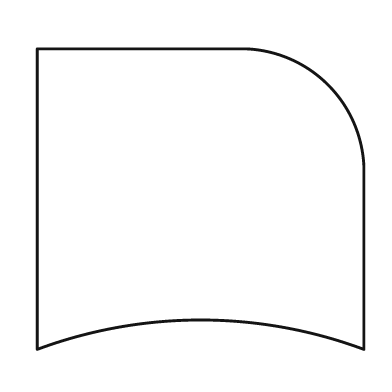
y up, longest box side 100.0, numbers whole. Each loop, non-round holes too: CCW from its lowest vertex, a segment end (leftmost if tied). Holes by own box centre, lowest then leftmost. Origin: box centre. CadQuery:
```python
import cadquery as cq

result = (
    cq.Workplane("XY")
    .moveTo(-50.0, -46.0)
    .threePointArc((0.0, -37.0), (50.0, -46.0))
    .lineTo(50.0, 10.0)
    .threePointArc((39.0, 35.0), (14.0, 46.0))
    .lineTo(-50.0, 46.0)
    .close()
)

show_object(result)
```